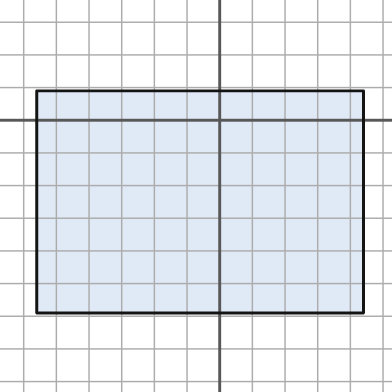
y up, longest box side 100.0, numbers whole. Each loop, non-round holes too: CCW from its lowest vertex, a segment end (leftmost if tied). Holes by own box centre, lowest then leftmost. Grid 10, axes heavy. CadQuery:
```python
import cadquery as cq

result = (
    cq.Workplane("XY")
    .moveTo(-56.0, -59.0)
    .lineTo(44.0, -59.0)
    .lineTo(44.0, 9.0)
    .lineTo(-56.0, 9.0)
    .close()
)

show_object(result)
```